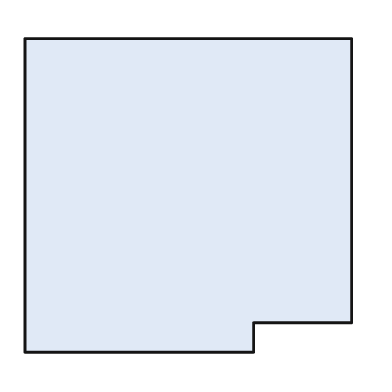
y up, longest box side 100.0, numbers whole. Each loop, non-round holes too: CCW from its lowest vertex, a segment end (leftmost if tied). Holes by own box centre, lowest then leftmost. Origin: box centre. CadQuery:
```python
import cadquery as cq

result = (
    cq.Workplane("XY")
    .moveTo(-50.0, -48.0)
    .lineTo(20.0, -48.0)
    .lineTo(20.0, -39.0)
    .lineTo(50.0, -39.0)
    .lineTo(50.0, 48.0)
    .lineTo(-50.0, 48.0)
    .close()
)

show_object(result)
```